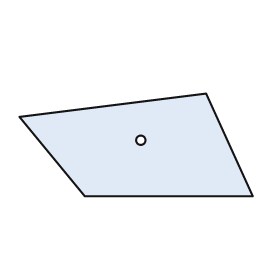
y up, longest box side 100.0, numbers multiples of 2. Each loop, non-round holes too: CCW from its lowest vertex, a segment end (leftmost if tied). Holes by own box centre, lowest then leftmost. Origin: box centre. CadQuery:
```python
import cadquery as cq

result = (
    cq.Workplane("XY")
    .moveTo(-22.0, -22.0)
    .lineTo(50.0, -22.0)
    .lineTo(30.0, 22.0)
    .lineTo(-50.0, 12.0)
    .close()
    .moveTo(2.0, 2.0)
    .circle(2.0)
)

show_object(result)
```